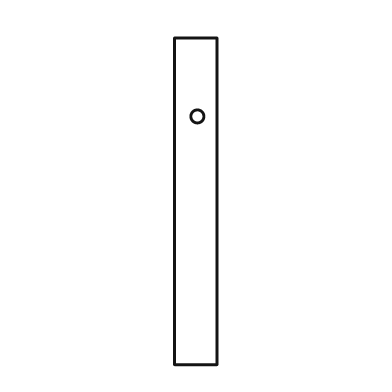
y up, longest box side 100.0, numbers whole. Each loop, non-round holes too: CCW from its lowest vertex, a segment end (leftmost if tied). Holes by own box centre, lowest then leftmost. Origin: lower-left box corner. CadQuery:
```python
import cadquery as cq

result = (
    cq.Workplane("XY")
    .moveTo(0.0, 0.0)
    .lineTo(13.0, 0.0)
    .lineTo(13.0, 100.0)
    .lineTo(0.0, 100.0)
    .close()
    .moveTo(7.0, 76.0)
    .circle(2.0)
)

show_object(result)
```